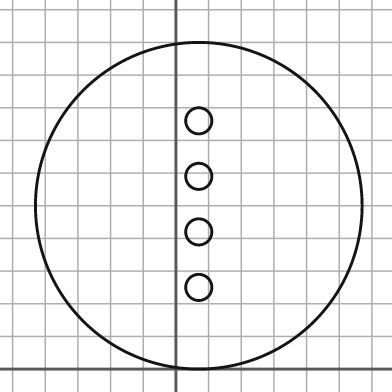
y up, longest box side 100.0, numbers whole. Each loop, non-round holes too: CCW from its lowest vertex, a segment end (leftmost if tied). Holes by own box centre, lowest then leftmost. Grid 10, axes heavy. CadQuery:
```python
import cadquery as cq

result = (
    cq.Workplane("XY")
    .moveTo(7.0, 50.0)
    .circle(50.0)
    .moveTo(7.0, 25.0)
    .circle(4.0)
    .moveTo(7.0, 42.0)
    .circle(4.0)
    .moveTo(7.0, 59.0)
    .circle(4.0)
    .moveTo(7.0, 76.0)
    .circle(4.0)
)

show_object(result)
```